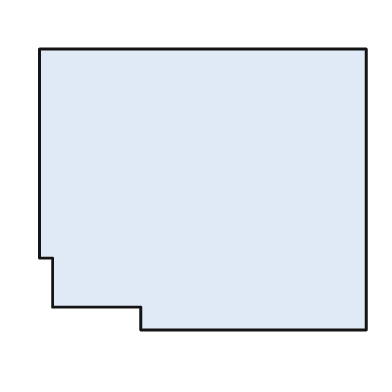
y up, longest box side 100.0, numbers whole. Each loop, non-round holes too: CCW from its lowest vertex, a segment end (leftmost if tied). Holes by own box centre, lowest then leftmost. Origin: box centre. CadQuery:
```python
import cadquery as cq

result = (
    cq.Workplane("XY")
    .moveTo(-19.0, -43.0)
    .lineTo(50.0, -43.0)
    .lineTo(50.0, 43.0)
    .lineTo(-50.0, 43.0)
    .lineTo(-50.0, -21.0)
    .lineTo(-46.0, -21.0)
    .lineTo(-46.0, -36.0)
    .lineTo(-19.0, -36.0)
    .close()
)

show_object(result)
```